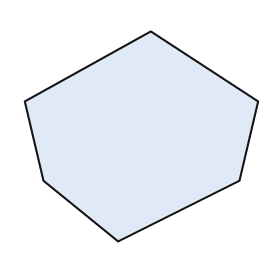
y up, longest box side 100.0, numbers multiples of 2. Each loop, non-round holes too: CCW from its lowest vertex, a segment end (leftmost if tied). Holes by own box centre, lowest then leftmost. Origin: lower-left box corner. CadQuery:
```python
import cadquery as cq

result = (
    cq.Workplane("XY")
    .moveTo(40.0, 0.0)
    .lineTo(92.0, 26.0)
    .lineTo(100.0, 60.0)
    .lineTo(54.0, 90.0)
    .lineTo(0.0, 60.0)
    .lineTo(8.0, 26.0)
    .close()
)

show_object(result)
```